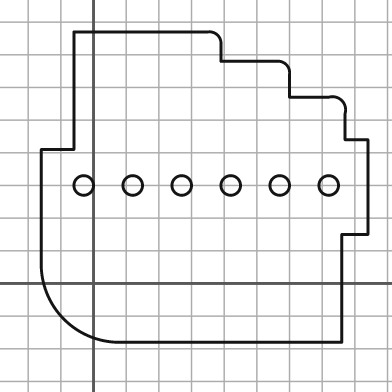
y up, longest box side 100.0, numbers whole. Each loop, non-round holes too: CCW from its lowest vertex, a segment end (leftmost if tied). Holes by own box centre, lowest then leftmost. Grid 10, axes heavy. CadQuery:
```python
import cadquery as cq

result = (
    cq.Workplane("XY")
    .moveTo(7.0, -18.0)
    .lineTo(76.0, -18.0)
    .lineTo(76.0, 15.0)
    .lineTo(84.0, 15.0)
    .lineTo(84.0, 44.0)
    .lineTo(77.0, 44.0)
    .lineTo(77.0, 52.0)
    .threePointArc((76.0, 56.0), (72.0, 57.0))
    .lineTo(60.0, 57.0)
    .lineTo(60.0, 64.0)
    .threePointArc((59.0, 67.0), (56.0, 68.0))
    .lineTo(39.0, 68.0)
    .lineTo(39.0, 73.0)
    .threePointArc((38.0, 76.0), (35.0, 77.0))
    .lineTo(-6.0, 77.0)
    .lineTo(-6.0, 41.0)
    .lineTo(-16.0, 41.0)
    .lineTo(-16.0, 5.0)
    .threePointArc((-9.0, -11.0), (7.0, -18.0))
    .close()
    .moveTo(-3.0, 30.0)
    .circle(3.0)
    .moveTo(12.0, 30.0)
    .circle(3.0)
    .moveTo(27.0, 30.0)
    .circle(3.0)
    .moveTo(42.0, 30.0)
    .circle(3.0)
    .moveTo(57.0, 30.0)
    .circle(3.0)
    .moveTo(72.0, 30.0)
    .circle(3.0)
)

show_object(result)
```